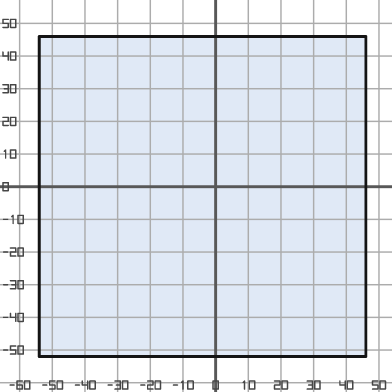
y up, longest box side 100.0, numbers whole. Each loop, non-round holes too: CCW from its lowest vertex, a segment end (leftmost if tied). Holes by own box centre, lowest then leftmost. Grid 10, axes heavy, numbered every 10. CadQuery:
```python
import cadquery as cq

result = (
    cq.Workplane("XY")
    .moveTo(-54.0, -52.0)
    .lineTo(46.0, -52.0)
    .lineTo(46.0, 46.0)
    .lineTo(-54.0, 46.0)
    .close()
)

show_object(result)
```